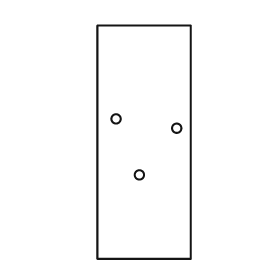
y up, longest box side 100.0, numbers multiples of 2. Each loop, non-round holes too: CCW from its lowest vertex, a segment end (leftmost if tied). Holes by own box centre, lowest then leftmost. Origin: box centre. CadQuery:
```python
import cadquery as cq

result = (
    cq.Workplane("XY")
    .moveTo(-20.0, -50.0)
    .lineTo(20.0, -50.0)
    .lineTo(20.0, 50.0)
    .lineTo(-20.0, 50.0)
    .close()
    .moveTo(-2.0, -14.0)
    .circle(2.0)
    .moveTo(14.0, 6.0)
    .circle(2.0)
    .moveTo(-12.0, 10.0)
    .circle(2.0)
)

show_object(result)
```